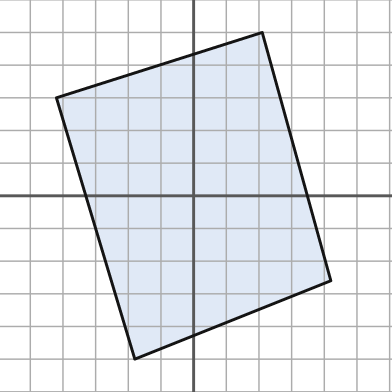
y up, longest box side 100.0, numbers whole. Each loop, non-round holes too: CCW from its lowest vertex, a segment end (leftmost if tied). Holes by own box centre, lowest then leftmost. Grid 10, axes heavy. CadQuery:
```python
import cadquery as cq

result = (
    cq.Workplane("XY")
    .moveTo(-18.0, -50.0)
    .lineTo(42.0, -26.0)
    .lineTo(21.0, 50.0)
    .lineTo(-42.0, 30.0)
    .close()
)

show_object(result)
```